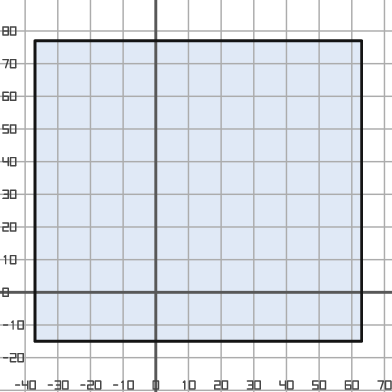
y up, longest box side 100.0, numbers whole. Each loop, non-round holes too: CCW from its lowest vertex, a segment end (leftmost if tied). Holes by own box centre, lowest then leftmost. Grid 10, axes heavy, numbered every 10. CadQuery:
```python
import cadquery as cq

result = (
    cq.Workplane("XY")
    .moveTo(-37.0, -15.0)
    .lineTo(63.0, -15.0)
    .lineTo(63.0, 77.0)
    .lineTo(-37.0, 77.0)
    .close()
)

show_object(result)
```